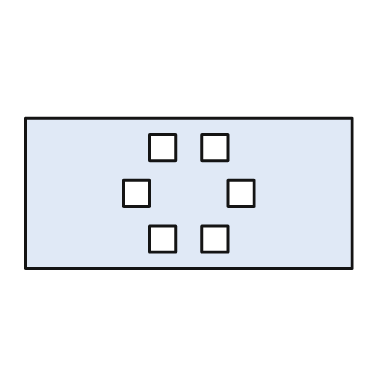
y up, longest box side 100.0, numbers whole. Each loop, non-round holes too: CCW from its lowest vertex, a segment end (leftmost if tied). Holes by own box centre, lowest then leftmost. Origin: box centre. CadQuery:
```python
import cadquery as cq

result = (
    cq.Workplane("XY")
    .moveTo(-50.0, -23.0)
    .lineTo(50.0, -23.0)
    .lineTo(50.0, 23.0)
    .lineTo(-50.0, 23.0)
    .close()
    .moveTo(-12.0, -18.0)
    .lineTo(-4.0, -18.0)
    .lineTo(-4.0, -10.0)
    .lineTo(-12.0, -10.0)
    .close()
    .moveTo(4.0, -18.0)
    .lineTo(12.0, -18.0)
    .lineTo(12.0, -10.0)
    .lineTo(4.0, -10.0)
    .close()
    .moveTo(-20.0, -4.0)
    .lineTo(-12.0, -4.0)
    .lineTo(-12.0, 4.0)
    .lineTo(-20.0, 4.0)
    .close()
    .moveTo(12.0, -4.0)
    .lineTo(20.0, -4.0)
    .lineTo(20.0, 4.0)
    .lineTo(12.0, 4.0)
    .close()
    .moveTo(-12.0, 10.0)
    .lineTo(-4.0, 10.0)
    .lineTo(-4.0, 18.0)
    .lineTo(-12.0, 18.0)
    .close()
    .moveTo(4.0, 10.0)
    .lineTo(12.0, 10.0)
    .lineTo(12.0, 18.0)
    .lineTo(4.0, 18.0)
    .close()
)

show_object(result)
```